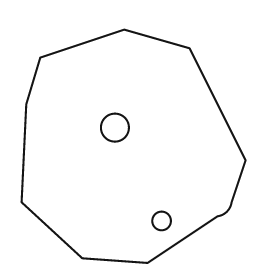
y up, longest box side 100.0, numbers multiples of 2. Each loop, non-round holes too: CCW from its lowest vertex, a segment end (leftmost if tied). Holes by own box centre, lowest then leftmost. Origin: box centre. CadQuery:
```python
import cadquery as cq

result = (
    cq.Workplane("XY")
    .moveTo(6.0, -50.0)
    .lineTo(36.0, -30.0)
    .threePointArc((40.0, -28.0), (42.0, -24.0))
    .lineTo(48.0, -6.0)
    .lineTo(24.0, 42.0)
    .lineTo(-4.0, 50.0)
    .lineTo(-40.0, 38.0)
    .lineTo(-46.0, 18.0)
    .lineTo(-48.0, -24.0)
    .lineTo(-22.0, -48.0)
    .close()
    .moveTo(12.0, -32.0)
    .circle(4.0)
    .moveTo(-8.0, 8.0)
    .circle(6.0)
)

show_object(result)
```